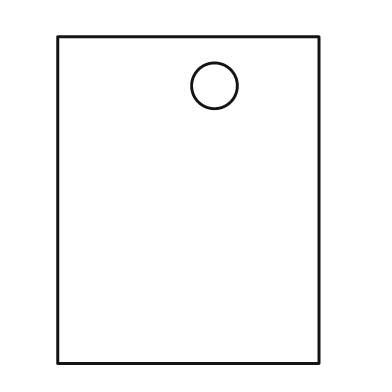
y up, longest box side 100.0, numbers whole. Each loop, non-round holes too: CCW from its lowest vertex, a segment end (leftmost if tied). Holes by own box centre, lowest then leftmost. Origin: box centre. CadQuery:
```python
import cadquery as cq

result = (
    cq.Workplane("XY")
    .moveTo(-40.0, -50.0)
    .lineTo(40.0, -50.0)
    .lineTo(40.0, 50.0)
    .lineTo(-40.0, 50.0)
    .close()
    .moveTo(8.0, 35.0)
    .circle(7.0)
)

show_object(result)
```